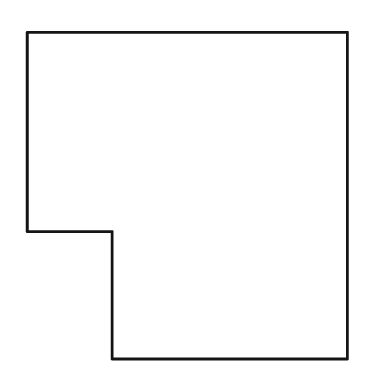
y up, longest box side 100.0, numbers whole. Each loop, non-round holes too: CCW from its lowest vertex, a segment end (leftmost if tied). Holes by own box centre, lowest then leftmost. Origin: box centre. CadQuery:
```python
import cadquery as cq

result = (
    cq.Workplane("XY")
    .moveTo(-23.0, -50.0)
    .lineTo(49.0, -50.0)
    .lineTo(49.0, 50.0)
    .lineTo(-49.0, 50.0)
    .lineTo(-49.0, -11.0)
    .lineTo(-23.0, -11.0)
    .close()
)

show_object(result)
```